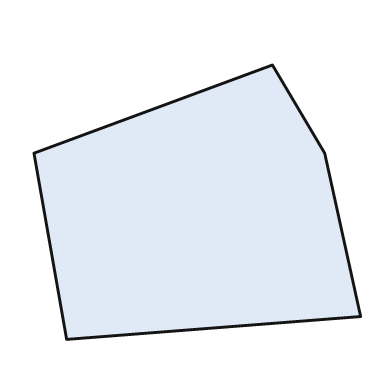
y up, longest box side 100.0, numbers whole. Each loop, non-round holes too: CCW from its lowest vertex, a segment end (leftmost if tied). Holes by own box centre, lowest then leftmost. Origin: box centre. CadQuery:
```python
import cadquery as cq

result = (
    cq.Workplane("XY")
    .moveTo(-40.0, -42.0)
    .lineTo(50.0, -35.0)
    .lineTo(39.0, 15.0)
    .lineTo(23.0, 42.0)
    .lineTo(-50.0, 15.0)
    .close()
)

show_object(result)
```